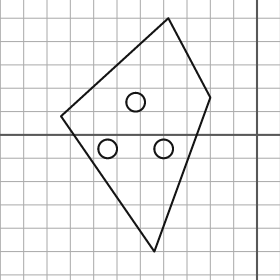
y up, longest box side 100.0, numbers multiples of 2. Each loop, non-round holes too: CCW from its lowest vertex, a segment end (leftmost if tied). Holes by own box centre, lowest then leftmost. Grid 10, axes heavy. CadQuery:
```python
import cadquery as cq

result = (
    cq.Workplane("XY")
    .moveTo(-44.0, -50.0)
    .lineTo(-20.0, 16.0)
    .lineTo(-38.0, 50.0)
    .lineTo(-84.0, 8.0)
    .close()
    .moveTo(-64.0, -6.0)
    .circle(4.0)
    .moveTo(-40.0, -6.0)
    .circle(4.0)
    .moveTo(-52.0, 14.0)
    .circle(4.0)
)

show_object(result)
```